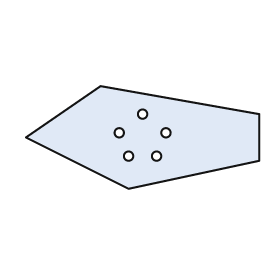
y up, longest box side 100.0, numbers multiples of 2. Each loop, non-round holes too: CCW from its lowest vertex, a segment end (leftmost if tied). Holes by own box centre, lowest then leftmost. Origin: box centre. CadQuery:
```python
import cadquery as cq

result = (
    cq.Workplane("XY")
    .moveTo(-6.0, -22.0)
    .lineTo(50.0, -10.0)
    .lineTo(50.0, 10.0)
    .lineTo(-18.0, 22.0)
    .lineTo(-50.0, 0.0)
    .close()
    .moveTo(-6.0, -8.0)
    .circle(2.0)
    .moveTo(6.0, -8.0)
    .circle(2.0)
    .moveTo(-10.0, 2.0)
    .circle(2.0)
    .moveTo(10.0, 2.0)
    .circle(2.0)
    .moveTo(0.0, 10.0)
    .circle(2.0)
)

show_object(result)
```